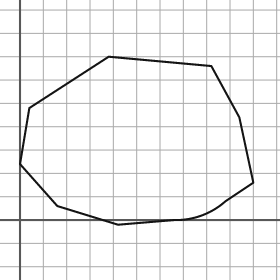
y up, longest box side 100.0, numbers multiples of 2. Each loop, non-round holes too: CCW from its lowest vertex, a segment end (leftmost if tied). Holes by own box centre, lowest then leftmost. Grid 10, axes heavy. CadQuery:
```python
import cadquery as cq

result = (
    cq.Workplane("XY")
    .moveTo(42.0, -2.0)
    .lineTo(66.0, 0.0)
    .threePointArc((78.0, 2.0), (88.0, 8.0))
    .lineTo(100.0, 16.0)
    .lineTo(94.0, 44.0)
    .lineTo(82.0, 66.0)
    .lineTo(38.0, 70.0)
    .lineTo(4.0, 48.0)
    .lineTo(0.0, 24.0)
    .lineTo(16.0, 6.0)
    .close()
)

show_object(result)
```